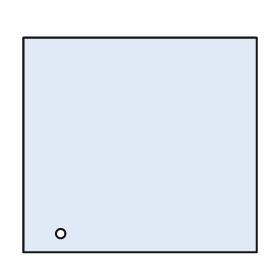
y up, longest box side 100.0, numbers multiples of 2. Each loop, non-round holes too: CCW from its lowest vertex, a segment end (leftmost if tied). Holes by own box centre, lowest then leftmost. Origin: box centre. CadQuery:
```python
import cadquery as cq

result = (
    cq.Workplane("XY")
    .moveTo(-50.0, -46.0)
    .lineTo(50.0, -46.0)
    .lineTo(50.0, 46.0)
    .lineTo(-50.0, 46.0)
    .close()
    .moveTo(-34.0, -38.0)
    .circle(2.0)
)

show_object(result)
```